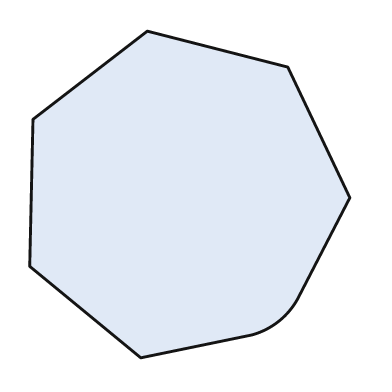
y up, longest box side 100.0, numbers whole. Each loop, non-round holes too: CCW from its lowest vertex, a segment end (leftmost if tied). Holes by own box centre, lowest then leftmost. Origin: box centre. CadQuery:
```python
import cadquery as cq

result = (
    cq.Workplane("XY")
    .moveTo(-15.0, -50.0)
    .lineTo(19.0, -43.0)
    .threePointArc((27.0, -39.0), (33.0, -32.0))
    .lineTo(49.0, -1.0)
    .lineTo(30.0, 39.0)
    .lineTo(-13.0, 50.0)
    .lineTo(-48.0, 23.0)
    .lineTo(-49.0, -22.0)
    .close()
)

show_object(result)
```